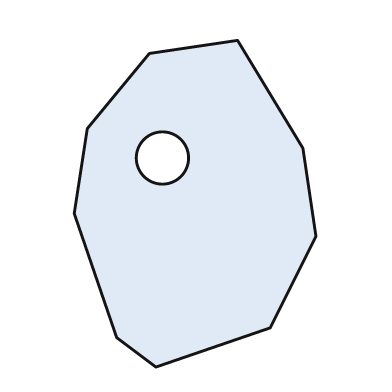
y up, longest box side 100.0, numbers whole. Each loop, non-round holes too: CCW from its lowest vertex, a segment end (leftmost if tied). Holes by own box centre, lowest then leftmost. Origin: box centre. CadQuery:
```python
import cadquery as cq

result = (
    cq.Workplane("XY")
    .moveTo(-12.0, -50.0)
    .lineTo(23.0, -38.0)
    .lineTo(37.0, -10.0)
    .lineTo(33.0, 17.0)
    .lineTo(13.0, 50.0)
    .lineTo(-14.0, 46.0)
    .lineTo(-33.0, 23.0)
    .lineTo(-37.0, -3.0)
    .lineTo(-24.0, -41.0)
    .close()
    .moveTo(-10.0, 14.0)
    .circle(8.0)
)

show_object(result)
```